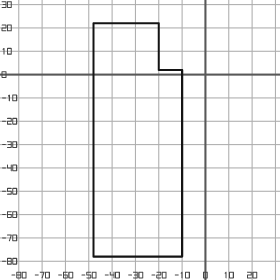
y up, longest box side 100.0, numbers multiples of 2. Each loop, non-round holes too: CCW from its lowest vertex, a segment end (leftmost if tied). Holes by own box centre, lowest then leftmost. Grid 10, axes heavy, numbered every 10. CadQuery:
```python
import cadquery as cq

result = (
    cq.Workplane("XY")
    .moveTo(-48.0, -78.0)
    .lineTo(-10.0, -78.0)
    .lineTo(-10.0, 2.0)
    .lineTo(-20.0, 2.0)
    .lineTo(-20.0, 22.0)
    .lineTo(-48.0, 22.0)
    .close()
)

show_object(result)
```